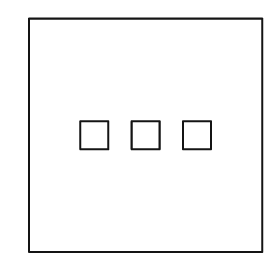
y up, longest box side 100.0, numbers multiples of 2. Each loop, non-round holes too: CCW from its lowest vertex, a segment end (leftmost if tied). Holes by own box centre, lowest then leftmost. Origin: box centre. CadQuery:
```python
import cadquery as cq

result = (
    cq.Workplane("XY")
    .moveTo(-50.0, -50.0)
    .lineTo(50.0, -50.0)
    .lineTo(50.0, 50.0)
    .lineTo(-50.0, 50.0)
    .close()
    .moveTo(-28.0, -6.0)
    .lineTo(-16.0, -6.0)
    .lineTo(-16.0, 6.0)
    .lineTo(-28.0, 6.0)
    .close()
    .moveTo(-6.0, -6.0)
    .lineTo(6.0, -6.0)
    .lineTo(6.0, 6.0)
    .lineTo(-6.0, 6.0)
    .close()
    .moveTo(16.0, -6.0)
    .lineTo(28.0, -6.0)
    .lineTo(28.0, 6.0)
    .lineTo(16.0, 6.0)
    .close()
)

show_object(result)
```